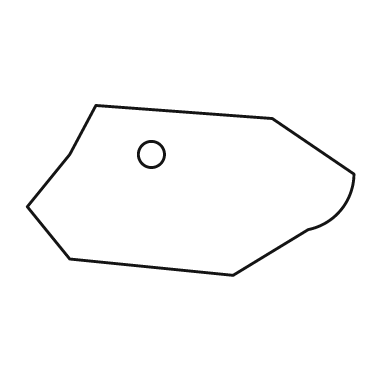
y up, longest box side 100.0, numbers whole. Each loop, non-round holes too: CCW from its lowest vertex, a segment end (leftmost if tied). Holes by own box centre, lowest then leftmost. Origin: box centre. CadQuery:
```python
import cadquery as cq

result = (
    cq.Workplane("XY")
    .moveTo(13.0, -26.0)
    .lineTo(36.0, -12.0)
    .threePointArc((46.0, -6.0), (50.0, 5.0))
    .lineTo(25.0, 22.0)
    .lineTo(-29.0, 26.0)
    .lineTo(-37.0, 11.0)
    .lineTo(-50.0, -5.0)
    .lineTo(-37.0, -21.0)
    .close()
    .moveTo(-12.0, 11.0)
    .circle(4.0)
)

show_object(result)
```